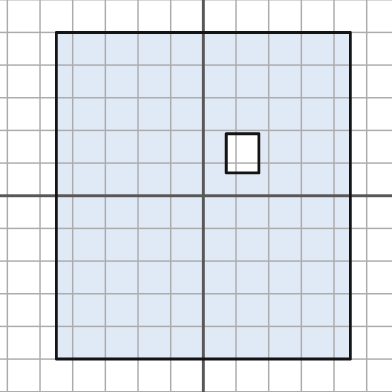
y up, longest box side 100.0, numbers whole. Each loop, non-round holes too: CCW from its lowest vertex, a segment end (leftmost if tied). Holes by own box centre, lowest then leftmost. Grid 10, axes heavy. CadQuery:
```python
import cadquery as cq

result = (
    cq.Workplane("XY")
    .moveTo(-45.0, -50.0)
    .lineTo(45.0, -50.0)
    .lineTo(45.0, 50.0)
    .lineTo(-45.0, 50.0)
    .close()
    .moveTo(7.0, 7.0)
    .lineTo(17.0, 7.0)
    .lineTo(17.0, 19.0)
    .lineTo(7.0, 19.0)
    .close()
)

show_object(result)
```